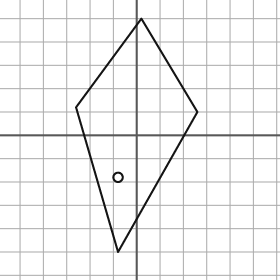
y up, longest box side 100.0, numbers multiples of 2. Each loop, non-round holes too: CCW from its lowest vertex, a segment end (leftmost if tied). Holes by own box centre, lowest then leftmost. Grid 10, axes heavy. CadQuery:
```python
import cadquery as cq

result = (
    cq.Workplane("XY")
    .moveTo(-8.0, -50.0)
    .lineTo(26.0, 10.0)
    .lineTo(2.0, 50.0)
    .lineTo(-26.0, 12.0)
    .close()
    .moveTo(-8.0, -18.0)
    .circle(2.0)
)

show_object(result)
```